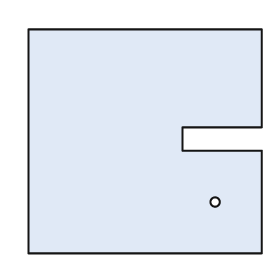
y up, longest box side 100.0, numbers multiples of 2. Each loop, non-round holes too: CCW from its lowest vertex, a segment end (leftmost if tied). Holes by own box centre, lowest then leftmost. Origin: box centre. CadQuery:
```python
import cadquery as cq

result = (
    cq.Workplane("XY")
    .moveTo(-50.0, -48.0)
    .lineTo(50.0, -48.0)
    .lineTo(50.0, -4.0)
    .lineTo(16.0, -4.0)
    .lineTo(16.0, 6.0)
    .lineTo(50.0, 6.0)
    .lineTo(50.0, 48.0)
    .lineTo(-50.0, 48.0)
    .close()
    .moveTo(30.0, -26.0)
    .circle(2.0)
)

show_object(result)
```